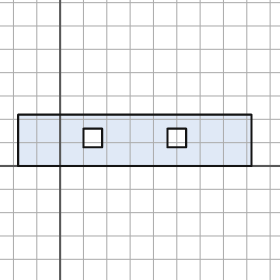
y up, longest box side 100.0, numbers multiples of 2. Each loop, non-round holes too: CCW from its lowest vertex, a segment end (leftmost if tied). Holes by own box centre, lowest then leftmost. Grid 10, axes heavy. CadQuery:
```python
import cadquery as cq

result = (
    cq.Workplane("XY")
    .moveTo(-18.0, 0.0)
    .lineTo(82.0, 0.0)
    .lineTo(82.0, 22.0)
    .lineTo(-18.0, 22.0)
    .close()
    .moveTo(10.0, 8.0)
    .lineTo(18.0, 8.0)
    .lineTo(18.0, 16.0)
    .lineTo(10.0, 16.0)
    .close()
    .moveTo(46.0, 8.0)
    .lineTo(54.0, 8.0)
    .lineTo(54.0, 16.0)
    .lineTo(46.0, 16.0)
    .close()
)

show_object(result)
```